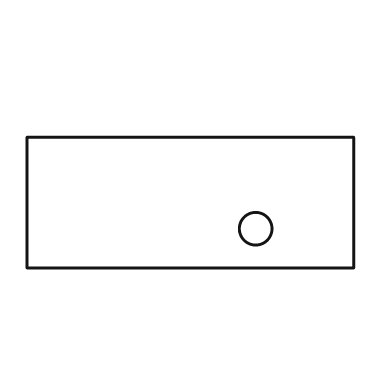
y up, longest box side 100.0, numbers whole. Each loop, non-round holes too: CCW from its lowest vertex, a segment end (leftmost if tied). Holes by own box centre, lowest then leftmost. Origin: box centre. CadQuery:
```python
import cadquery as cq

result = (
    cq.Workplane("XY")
    .moveTo(-50.0, -20.0)
    .lineTo(50.0, -20.0)
    .lineTo(50.0, 20.0)
    .lineTo(-50.0, 20.0)
    .close()
    .moveTo(20.0, -8.0)
    .circle(5.0)
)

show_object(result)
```